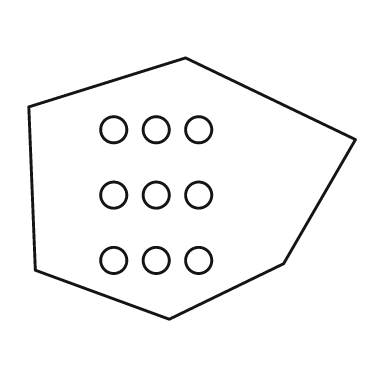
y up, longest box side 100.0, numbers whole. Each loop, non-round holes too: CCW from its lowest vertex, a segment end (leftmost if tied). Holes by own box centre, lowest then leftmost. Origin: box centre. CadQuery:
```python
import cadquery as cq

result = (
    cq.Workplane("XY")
    .moveTo(-7.0, -40.0)
    .lineTo(28.0, -23.0)
    .lineTo(50.0, 15.0)
    .lineTo(-2.0, 40.0)
    .lineTo(-50.0, 25.0)
    .lineTo(-48.0, -25.0)
    .close()
    .moveTo(-24.0, -22.0)
    .circle(4.0)
    .moveTo(-11.0, -22.0)
    .circle(4.0)
    .moveTo(2.0, -22.0)
    .circle(4.0)
    .moveTo(-24.0, -2.0)
    .circle(4.0)
    .moveTo(-11.0, -2.0)
    .circle(4.0)
    .moveTo(2.0, -2.0)
    .circle(4.0)
    .moveTo(-24.0, 18.0)
    .circle(4.0)
    .moveTo(-11.0, 18.0)
    .circle(4.0)
    .moveTo(2.0, 18.0)
    .circle(4.0)
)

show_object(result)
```